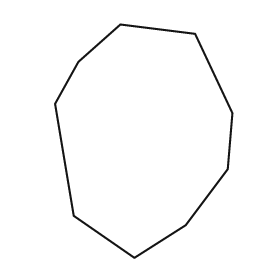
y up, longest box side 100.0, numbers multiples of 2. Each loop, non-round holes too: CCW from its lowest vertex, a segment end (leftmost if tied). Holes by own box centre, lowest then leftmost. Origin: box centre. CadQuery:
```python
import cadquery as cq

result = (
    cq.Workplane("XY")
    .moveTo(-4.0, -50.0)
    .lineTo(18.0, -36.0)
    .lineTo(36.0, -12.0)
    .lineTo(38.0, 12.0)
    .lineTo(22.0, 46.0)
    .lineTo(-10.0, 50.0)
    .lineTo(-28.0, 34.0)
    .lineTo(-38.0, 16.0)
    .lineTo(-30.0, -32.0)
    .close()
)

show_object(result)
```